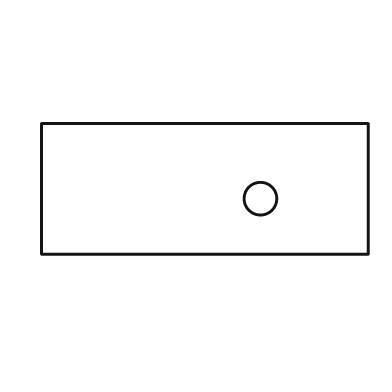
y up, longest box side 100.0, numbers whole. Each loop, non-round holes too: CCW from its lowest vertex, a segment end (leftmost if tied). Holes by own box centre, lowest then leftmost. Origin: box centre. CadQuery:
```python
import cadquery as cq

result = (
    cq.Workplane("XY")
    .moveTo(-50.0, -20.0)
    .lineTo(50.0, -20.0)
    .lineTo(50.0, 20.0)
    .lineTo(-50.0, 20.0)
    .close()
    .moveTo(17.0, -3.0)
    .circle(5.0)
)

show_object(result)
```